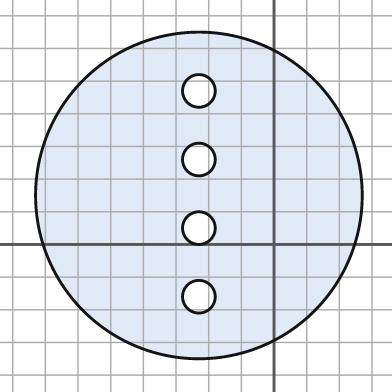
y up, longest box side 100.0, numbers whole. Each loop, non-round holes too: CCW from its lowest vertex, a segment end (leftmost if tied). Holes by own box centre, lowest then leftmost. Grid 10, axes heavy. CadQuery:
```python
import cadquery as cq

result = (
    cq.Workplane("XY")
    .moveTo(-23.0, 15.0)
    .circle(50.0)
    .moveTo(-23.0, -16.0)
    .circle(5.0)
    .moveTo(-23.0, 5.0)
    .circle(5.0)
    .moveTo(-23.0, 26.0)
    .circle(5.0)
    .moveTo(-23.0, 47.0)
    .circle(5.0)
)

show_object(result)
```